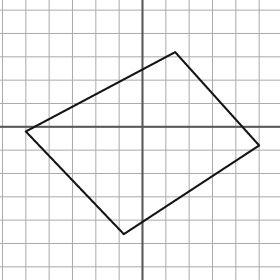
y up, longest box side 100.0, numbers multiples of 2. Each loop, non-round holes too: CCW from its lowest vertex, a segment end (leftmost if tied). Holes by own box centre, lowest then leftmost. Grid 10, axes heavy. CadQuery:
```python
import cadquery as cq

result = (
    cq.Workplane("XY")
    .moveTo(-8.0, -46.0)
    .lineTo(50.0, -8.0)
    .lineTo(14.0, 32.0)
    .lineTo(-50.0, -2.0)
    .close()
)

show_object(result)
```